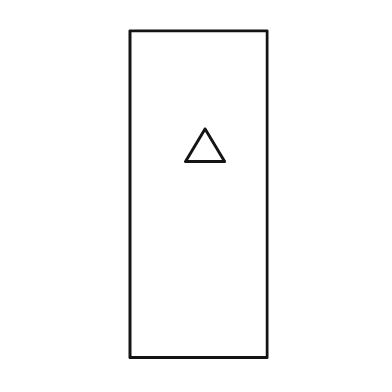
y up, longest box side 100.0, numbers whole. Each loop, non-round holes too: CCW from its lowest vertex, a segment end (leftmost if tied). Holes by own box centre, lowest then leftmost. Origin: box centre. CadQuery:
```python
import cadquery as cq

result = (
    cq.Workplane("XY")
    .moveTo(-21.0, -50.0)
    .lineTo(21.0, -50.0)
    .lineTo(21.0, 50.0)
    .lineTo(-21.0, 50.0)
    .close()
    .moveTo(-4.0, 10.0)
    .lineTo(8.0, 10.0)
    .lineTo(2.0, 20.0)
    .close()
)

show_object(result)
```